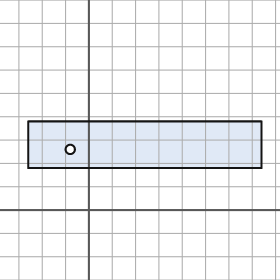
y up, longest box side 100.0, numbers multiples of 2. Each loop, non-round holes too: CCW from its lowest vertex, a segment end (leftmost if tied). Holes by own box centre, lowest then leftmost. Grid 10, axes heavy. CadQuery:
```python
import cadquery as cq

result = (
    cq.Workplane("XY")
    .moveTo(-26.0, 18.0)
    .lineTo(74.0, 18.0)
    .lineTo(74.0, 38.0)
    .lineTo(-26.0, 38.0)
    .close()
    .moveTo(-8.0, 26.0)
    .circle(2.0)
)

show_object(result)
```